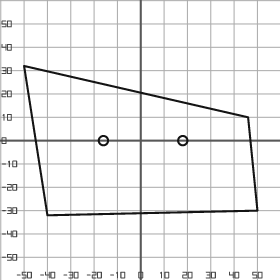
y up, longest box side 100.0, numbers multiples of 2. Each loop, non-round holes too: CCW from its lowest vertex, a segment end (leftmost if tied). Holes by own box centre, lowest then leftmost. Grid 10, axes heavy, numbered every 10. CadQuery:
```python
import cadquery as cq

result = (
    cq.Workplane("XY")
    .moveTo(-40.0, -32.0)
    .lineTo(50.0, -30.0)
    .lineTo(46.0, 10.0)
    .lineTo(-50.0, 32.0)
    .close()
    .moveTo(-16.0, 0.0)
    .circle(2.0)
    .moveTo(18.0, 0.0)
    .circle(2.0)
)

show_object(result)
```